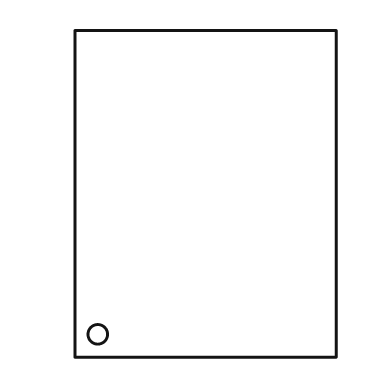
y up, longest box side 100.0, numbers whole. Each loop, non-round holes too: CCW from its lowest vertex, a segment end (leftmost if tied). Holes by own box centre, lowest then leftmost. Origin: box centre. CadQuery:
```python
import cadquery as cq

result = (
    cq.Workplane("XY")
    .moveTo(-40.0, -50.0)
    .lineTo(40.0, -50.0)
    .lineTo(40.0, 50.0)
    .lineTo(-40.0, 50.0)
    .close()
    .moveTo(-33.0, -43.0)
    .circle(3.0)
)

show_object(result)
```